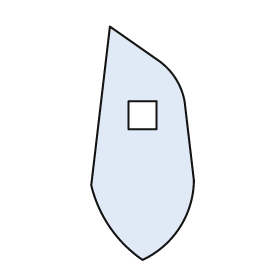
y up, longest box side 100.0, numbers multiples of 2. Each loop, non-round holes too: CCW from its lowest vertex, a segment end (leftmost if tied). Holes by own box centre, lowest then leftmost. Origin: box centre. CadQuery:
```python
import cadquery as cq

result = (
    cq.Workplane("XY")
    .moveTo(0.0, -50.0)
    .threePointArc((16.0, -36.0), (22.0, -16.0))
    .lineTo(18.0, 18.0)
    .threePointArc((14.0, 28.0), (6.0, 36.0))
    .lineTo(-14.0, 50.0)
    .lineTo(-22.0, -18.0)
    .threePointArc((-14.0, -36.0), (0.0, -50.0))
    .close()
    .moveTo(-6.0, 6.0)
    .lineTo(6.0, 6.0)
    .lineTo(6.0, 18.0)
    .lineTo(-6.0, 18.0)
    .close()
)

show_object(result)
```